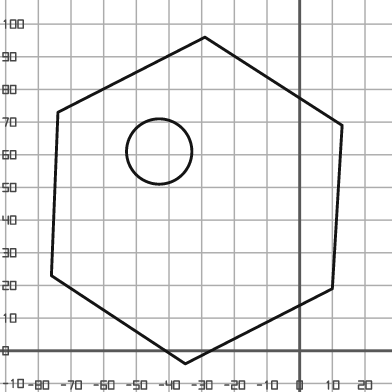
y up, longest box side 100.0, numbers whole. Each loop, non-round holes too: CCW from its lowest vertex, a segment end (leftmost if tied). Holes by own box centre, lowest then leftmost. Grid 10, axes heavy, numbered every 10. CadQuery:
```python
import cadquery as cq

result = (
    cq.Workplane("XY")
    .moveTo(-35.0, -4.0)
    .lineTo(10.0, 19.0)
    .lineTo(13.0, 69.0)
    .lineTo(-29.0, 96.0)
    .lineTo(-74.0, 73.0)
    .lineTo(-76.0, 23.0)
    .close()
    .moveTo(-43.0, 61.0)
    .circle(10.0)
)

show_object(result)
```